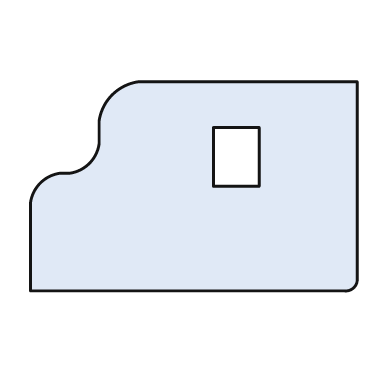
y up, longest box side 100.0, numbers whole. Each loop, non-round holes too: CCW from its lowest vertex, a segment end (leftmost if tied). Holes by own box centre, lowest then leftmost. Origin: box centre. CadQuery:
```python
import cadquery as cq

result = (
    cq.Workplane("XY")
    .moveTo(-50.0, -32.0)
    .lineTo(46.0, -32.0)
    .threePointArc((49.0, -31.0), (50.0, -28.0))
    .lineTo(50.0, 32.0)
    .lineTo(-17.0, 32.0)
    .threePointArc((-25.0, 28.0), (-29.0, 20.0))
    .lineTo(-29.0, 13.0)
    .threePointArc((-32.0, 7.0), (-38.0, 4.0))
    .lineTo(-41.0, 4.0)
    .threePointArc((-47.0, 1.0), (-50.0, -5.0))
    .close()
    .moveTo(6.0, 0.0)
    .lineTo(20.0, 0.0)
    .lineTo(20.0, 18.0)
    .lineTo(6.0, 18.0)
    .close()
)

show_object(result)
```